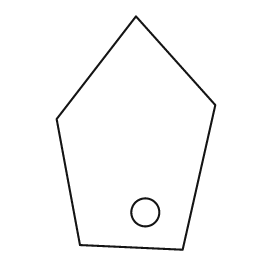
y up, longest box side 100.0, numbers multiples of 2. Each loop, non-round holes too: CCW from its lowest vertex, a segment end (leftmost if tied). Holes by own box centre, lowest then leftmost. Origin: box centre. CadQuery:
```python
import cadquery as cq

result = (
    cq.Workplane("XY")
    .moveTo(20.0, -50.0)
    .lineTo(34.0, 12.0)
    .lineTo(0.0, 50.0)
    .lineTo(-34.0, 6.0)
    .lineTo(-24.0, -48.0)
    .close()
    .moveTo(4.0, -34.0)
    .circle(6.0)
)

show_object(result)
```